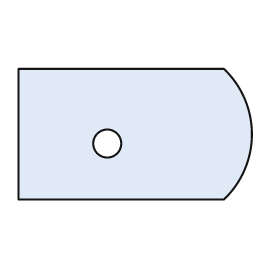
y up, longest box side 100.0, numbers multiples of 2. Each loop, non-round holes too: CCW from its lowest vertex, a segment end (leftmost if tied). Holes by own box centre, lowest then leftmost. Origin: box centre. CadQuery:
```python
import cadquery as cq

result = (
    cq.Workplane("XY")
    .moveTo(-50.0, -28.0)
    .lineTo(38.0, -28.0)
    .threePointArc((50.0, 0.0), (38.0, 28.0))
    .lineTo(-50.0, 28.0)
    .close()
    .moveTo(-12.0, -4.0)
    .circle(6.0)
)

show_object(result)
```